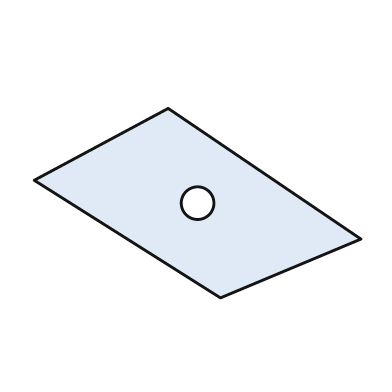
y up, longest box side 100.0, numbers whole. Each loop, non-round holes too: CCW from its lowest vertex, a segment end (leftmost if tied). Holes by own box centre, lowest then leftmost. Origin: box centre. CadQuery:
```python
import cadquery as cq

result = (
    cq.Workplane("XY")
    .moveTo(7.0, -29.0)
    .lineTo(50.0, -11.0)
    .lineTo(-9.0, 29.0)
    .lineTo(-50.0, 7.0)
    .close()
    .moveTo(0.0, 0.0)
    .circle(5.0)
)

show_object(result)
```